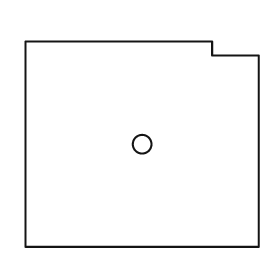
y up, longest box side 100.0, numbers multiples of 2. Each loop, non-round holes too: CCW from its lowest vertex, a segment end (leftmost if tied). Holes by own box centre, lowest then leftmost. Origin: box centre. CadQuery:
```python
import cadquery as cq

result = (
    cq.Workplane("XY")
    .moveTo(-50.0, -44.0)
    .lineTo(50.0, -44.0)
    .lineTo(50.0, 38.0)
    .lineTo(30.0, 38.0)
    .lineTo(30.0, 44.0)
    .lineTo(-50.0, 44.0)
    .close()
    .moveTo(0.0, 0.0)
    .circle(4.0)
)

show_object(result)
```